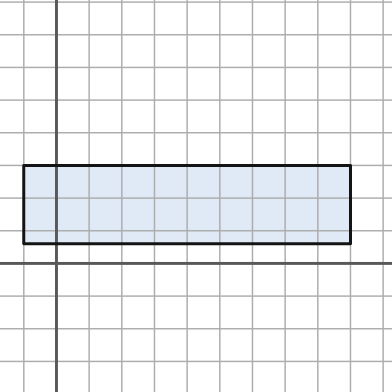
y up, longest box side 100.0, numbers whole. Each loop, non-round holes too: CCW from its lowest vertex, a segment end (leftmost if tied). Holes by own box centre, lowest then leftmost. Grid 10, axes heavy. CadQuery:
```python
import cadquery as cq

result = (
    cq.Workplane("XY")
    .moveTo(-10.0, 6.0)
    .lineTo(90.0, 6.0)
    .lineTo(90.0, 30.0)
    .lineTo(-10.0, 30.0)
    .close()
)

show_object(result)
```